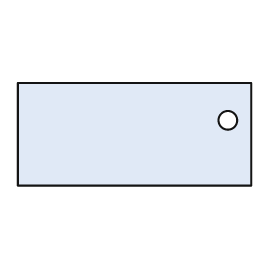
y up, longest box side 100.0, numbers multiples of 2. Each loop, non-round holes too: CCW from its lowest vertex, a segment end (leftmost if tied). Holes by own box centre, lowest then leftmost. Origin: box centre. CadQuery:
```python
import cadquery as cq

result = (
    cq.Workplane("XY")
    .moveTo(-50.0, -22.0)
    .lineTo(50.0, -22.0)
    .lineTo(50.0, 22.0)
    .lineTo(-50.0, 22.0)
    .close()
    .moveTo(40.0, 6.0)
    .circle(4.0)
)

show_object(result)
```